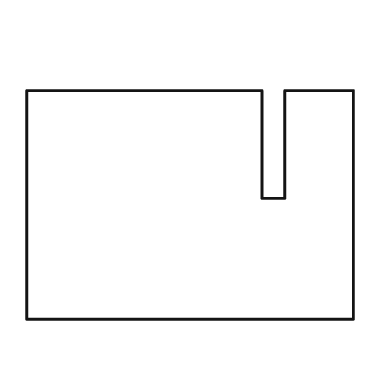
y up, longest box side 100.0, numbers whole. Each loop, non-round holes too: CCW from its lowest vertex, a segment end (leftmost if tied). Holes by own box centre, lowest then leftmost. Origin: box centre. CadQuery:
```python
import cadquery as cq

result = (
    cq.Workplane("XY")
    .moveTo(-50.0, -35.0)
    .lineTo(50.0, -35.0)
    .lineTo(50.0, 35.0)
    .lineTo(29.0, 35.0)
    .lineTo(29.0, 2.0)
    .lineTo(22.0, 2.0)
    .lineTo(22.0, 35.0)
    .lineTo(-50.0, 35.0)
    .close()
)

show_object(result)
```